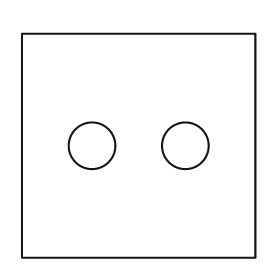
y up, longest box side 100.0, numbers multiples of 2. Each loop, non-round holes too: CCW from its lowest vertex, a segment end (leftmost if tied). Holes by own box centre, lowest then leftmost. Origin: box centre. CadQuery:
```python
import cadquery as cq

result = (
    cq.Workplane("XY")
    .moveTo(-50.0, -48.0)
    .lineTo(50.0, -48.0)
    .lineTo(50.0, 48.0)
    .lineTo(-50.0, 48.0)
    .close()
    .moveTo(-20.0, 0.0)
    .circle(10.0)
    .moveTo(20.0, 0.0)
    .circle(10.0)
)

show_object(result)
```